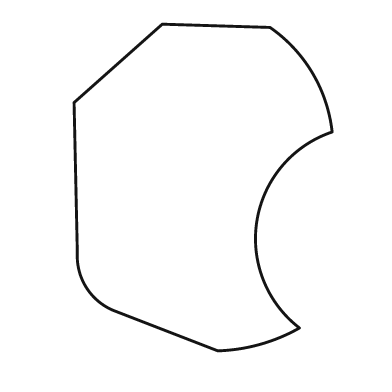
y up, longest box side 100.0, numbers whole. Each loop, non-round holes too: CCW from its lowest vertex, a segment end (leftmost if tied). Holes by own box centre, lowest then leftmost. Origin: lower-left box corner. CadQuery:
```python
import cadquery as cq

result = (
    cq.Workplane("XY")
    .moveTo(44.0, 0.0)
    .threePointArc((57.0, 2.0), (69.0, 7.0))
    .threePointArc((56.0, 40.0), (79.0, 67.0))
    .threePointArc((73.0, 85.0), (60.0, 99.0))
    .lineTo(27.0, 100.0)
    .lineTo(0.0, 76.0)
    .lineTo(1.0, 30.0)
    .threePointArc((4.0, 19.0), (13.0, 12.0))
    .close()
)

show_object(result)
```